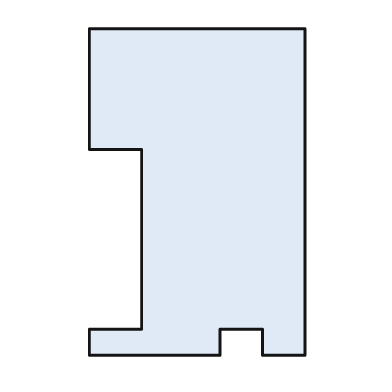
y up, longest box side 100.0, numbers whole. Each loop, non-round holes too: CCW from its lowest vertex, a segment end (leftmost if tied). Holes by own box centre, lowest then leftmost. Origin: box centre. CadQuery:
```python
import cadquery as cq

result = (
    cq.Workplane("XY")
    .moveTo(-33.0, -50.0)
    .lineTo(7.0, -50.0)
    .lineTo(7.0, -42.0)
    .lineTo(20.0, -42.0)
    .lineTo(20.0, -50.0)
    .lineTo(33.0, -50.0)
    .lineTo(33.0, 50.0)
    .lineTo(-33.0, 50.0)
    .lineTo(-33.0, 13.0)
    .lineTo(-17.0, 13.0)
    .lineTo(-17.0, -42.0)
    .lineTo(-33.0, -42.0)
    .close()
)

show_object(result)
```